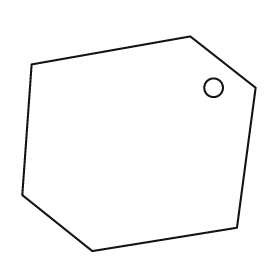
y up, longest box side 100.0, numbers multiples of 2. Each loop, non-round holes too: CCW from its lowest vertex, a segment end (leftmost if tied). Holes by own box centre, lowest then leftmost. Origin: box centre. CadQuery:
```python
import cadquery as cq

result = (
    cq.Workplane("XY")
    .moveTo(-20.0, -46.0)
    .lineTo(42.0, -36.0)
    .lineTo(50.0, 24.0)
    .lineTo(22.0, 46.0)
    .lineTo(-46.0, 34.0)
    .lineTo(-50.0, -22.0)
    .close()
    .moveTo(32.0, 24.0)
    .circle(4.0)
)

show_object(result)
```